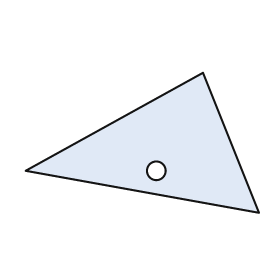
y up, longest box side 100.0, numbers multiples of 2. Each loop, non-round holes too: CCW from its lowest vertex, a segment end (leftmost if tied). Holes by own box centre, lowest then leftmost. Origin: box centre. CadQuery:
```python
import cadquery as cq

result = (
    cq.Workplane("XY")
    .moveTo(50.0, -30.0)
    .lineTo(26.0, 30.0)
    .lineTo(-50.0, -12.0)
    .close()
    .moveTo(6.0, -12.0)
    .circle(4.0)
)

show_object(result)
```